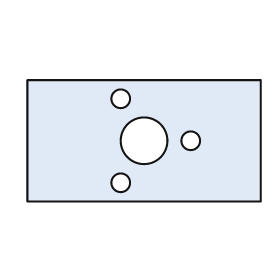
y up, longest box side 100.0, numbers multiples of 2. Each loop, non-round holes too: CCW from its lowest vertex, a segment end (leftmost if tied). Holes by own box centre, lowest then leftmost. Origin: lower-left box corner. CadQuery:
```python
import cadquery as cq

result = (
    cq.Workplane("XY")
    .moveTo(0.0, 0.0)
    .lineTo(100.0, 0.0)
    .lineTo(100.0, 52.0)
    .lineTo(0.0, 52.0)
    .close()
    .moveTo(40.0, 8.0)
    .circle(4.0)
    .moveTo(50.0, 26.0)
    .circle(10.0)
    .moveTo(70.0, 26.0)
    .circle(4.0)
    .moveTo(40.0, 44.0)
    .circle(4.0)
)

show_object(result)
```